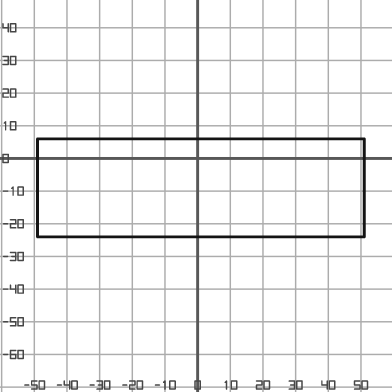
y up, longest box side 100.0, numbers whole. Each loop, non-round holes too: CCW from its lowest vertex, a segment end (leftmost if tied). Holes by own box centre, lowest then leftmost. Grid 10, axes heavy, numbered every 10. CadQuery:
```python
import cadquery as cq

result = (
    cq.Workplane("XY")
    .moveTo(-49.0, -24.0)
    .lineTo(51.0, -24.0)
    .lineTo(51.0, 6.0)
    .lineTo(-49.0, 6.0)
    .close()
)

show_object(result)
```